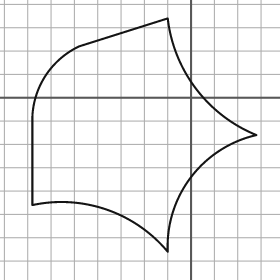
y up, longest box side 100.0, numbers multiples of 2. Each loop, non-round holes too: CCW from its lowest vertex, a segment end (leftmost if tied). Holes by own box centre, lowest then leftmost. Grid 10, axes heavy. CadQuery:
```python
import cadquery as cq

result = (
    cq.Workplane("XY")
    .moveTo(-10.0, -66.0)
    .threePointArc((0.0, -34.0), (28.0, -16.0))
    .threePointArc((2.0, 4.0), (-10.0, 34.0))
    .lineTo(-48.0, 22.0)
    .threePointArc((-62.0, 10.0), (-68.0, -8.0))
    .lineTo(-68.0, -46.0)
    .threePointArc((-36.0, -48.0), (-10.0, -66.0))
    .close()
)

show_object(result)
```